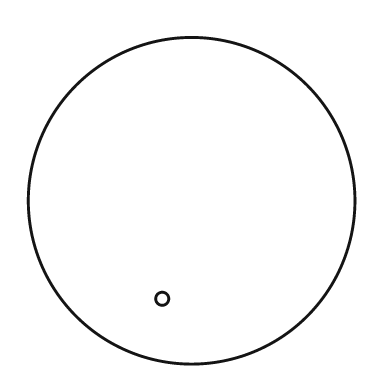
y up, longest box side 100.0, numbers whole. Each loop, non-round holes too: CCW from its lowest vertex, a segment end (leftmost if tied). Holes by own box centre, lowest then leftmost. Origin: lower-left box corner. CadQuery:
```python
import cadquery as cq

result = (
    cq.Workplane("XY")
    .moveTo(50.0, 50.0)
    .circle(50.0)
    .moveTo(41.0, 20.0)
    .circle(2.0)
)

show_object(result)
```